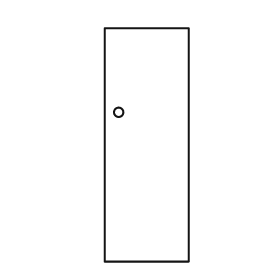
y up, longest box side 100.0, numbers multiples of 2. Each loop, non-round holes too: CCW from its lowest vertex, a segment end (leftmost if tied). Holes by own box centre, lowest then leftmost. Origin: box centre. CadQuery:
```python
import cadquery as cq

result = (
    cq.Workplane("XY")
    .moveTo(-18.0, -50.0)
    .lineTo(18.0, -50.0)
    .lineTo(18.0, 50.0)
    .lineTo(-18.0, 50.0)
    .close()
    .moveTo(-12.0, 14.0)
    .circle(2.0)
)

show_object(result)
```